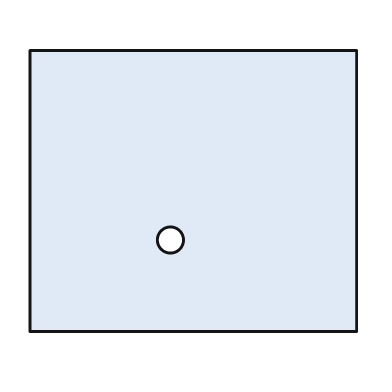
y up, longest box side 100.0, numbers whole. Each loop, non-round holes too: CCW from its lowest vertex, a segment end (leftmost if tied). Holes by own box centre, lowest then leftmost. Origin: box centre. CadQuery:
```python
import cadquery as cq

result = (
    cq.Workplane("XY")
    .moveTo(-50.0, -43.0)
    .lineTo(50.0, -43.0)
    .lineTo(50.0, 43.0)
    .lineTo(-50.0, 43.0)
    .close()
    .moveTo(-7.0, -15.0)
    .circle(4.0)
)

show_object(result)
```